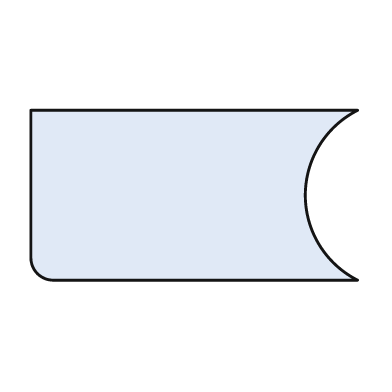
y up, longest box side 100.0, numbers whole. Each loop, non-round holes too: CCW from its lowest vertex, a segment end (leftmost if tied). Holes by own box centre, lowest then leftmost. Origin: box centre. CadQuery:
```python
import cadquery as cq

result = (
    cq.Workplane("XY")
    .moveTo(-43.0, -26.0)
    .lineTo(50.0, -26.0)
    .threePointArc((34.0, 0.0), (50.0, 26.0))
    .lineTo(-50.0, 26.0)
    .lineTo(-50.0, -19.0)
    .threePointArc((-48.0, -24.0), (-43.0, -26.0))
    .close()
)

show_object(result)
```